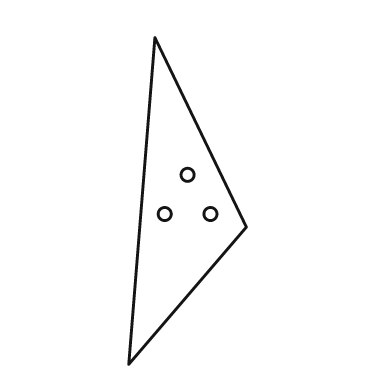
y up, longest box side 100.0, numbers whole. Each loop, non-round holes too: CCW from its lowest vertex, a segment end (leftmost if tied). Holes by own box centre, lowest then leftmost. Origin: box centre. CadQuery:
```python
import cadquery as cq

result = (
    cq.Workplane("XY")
    .moveTo(-18.0, -50.0)
    .lineTo(18.0, -8.0)
    .lineTo(-10.0, 50.0)
    .close()
    .moveTo(-7.0, -4.0)
    .circle(2.0)
    .moveTo(7.0, -4.0)
    .circle(2.0)
    .moveTo(0.0, 8.0)
    .circle(2.0)
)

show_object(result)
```